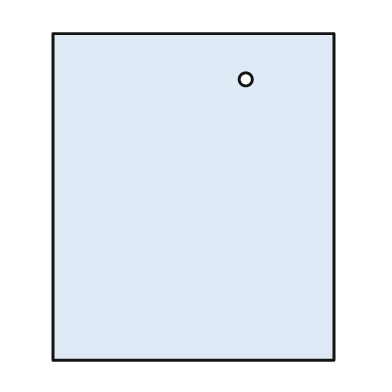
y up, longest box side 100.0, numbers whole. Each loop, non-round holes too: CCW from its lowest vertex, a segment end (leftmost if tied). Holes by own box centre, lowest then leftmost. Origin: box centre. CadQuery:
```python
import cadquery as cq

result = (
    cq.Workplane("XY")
    .moveTo(-43.0, -50.0)
    .lineTo(43.0, -50.0)
    .lineTo(43.0, 50.0)
    .lineTo(-43.0, 50.0)
    .close()
    .moveTo(16.0, 36.0)
    .circle(2.0)
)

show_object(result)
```